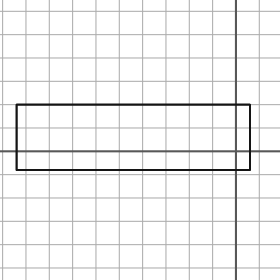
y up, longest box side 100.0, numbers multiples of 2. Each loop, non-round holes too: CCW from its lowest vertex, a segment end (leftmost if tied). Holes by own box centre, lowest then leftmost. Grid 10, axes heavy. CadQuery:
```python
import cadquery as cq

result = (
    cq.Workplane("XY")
    .moveTo(-94.0, -8.0)
    .lineTo(6.0, -8.0)
    .lineTo(6.0, 20.0)
    .lineTo(-94.0, 20.0)
    .close()
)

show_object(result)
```